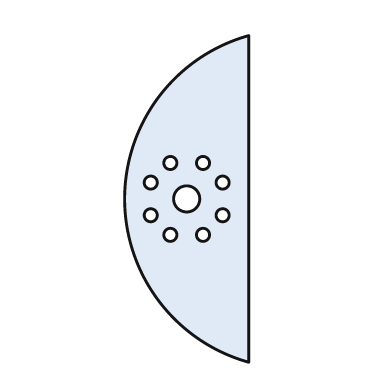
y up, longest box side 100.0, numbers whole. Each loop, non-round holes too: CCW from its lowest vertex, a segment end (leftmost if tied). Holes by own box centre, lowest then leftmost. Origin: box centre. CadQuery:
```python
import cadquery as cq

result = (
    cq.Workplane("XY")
    .moveTo(19.0, -50.0)
    .lineTo(19.0, 50.0)
    .threePointArc((-19.0, 0.0), (19.0, -50.0))
    .close()
    .moveTo(-5.0, -11.0)
    .circle(2.0)
    .moveTo(5.0, -11.0)
    .circle(2.0)
    .moveTo(-11.0, -5.0)
    .circle(2.0)
    .moveTo(11.0, -5.0)
    .circle(2.0)
    .moveTo(0.0, 0.0)
    .circle(4.0)
    .moveTo(-11.0, 5.0)
    .circle(2.0)
    .moveTo(11.0, 5.0)
    .circle(2.0)
    .moveTo(-5.0, 11.0)
    .circle(2.0)
    .moveTo(5.0, 11.0)
    .circle(2.0)
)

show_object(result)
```